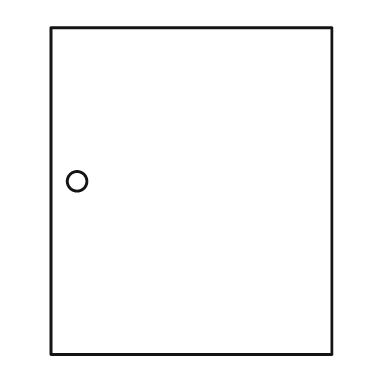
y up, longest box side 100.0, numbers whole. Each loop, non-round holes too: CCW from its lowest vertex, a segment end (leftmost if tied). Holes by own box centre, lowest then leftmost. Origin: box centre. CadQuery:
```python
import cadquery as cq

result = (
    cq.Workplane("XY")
    .moveTo(-43.0, -50.0)
    .lineTo(43.0, -50.0)
    .lineTo(43.0, 50.0)
    .lineTo(-43.0, 50.0)
    .close()
    .moveTo(-35.0, 3.0)
    .circle(3.0)
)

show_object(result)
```